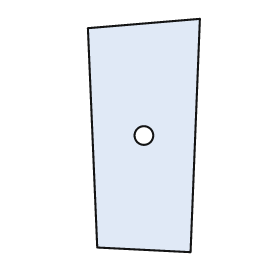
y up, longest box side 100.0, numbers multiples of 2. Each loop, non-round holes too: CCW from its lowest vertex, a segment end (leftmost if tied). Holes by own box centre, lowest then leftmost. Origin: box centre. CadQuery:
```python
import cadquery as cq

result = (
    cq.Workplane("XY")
    .moveTo(20.0, -50.0)
    .lineTo(24.0, 50.0)
    .lineTo(-24.0, 46.0)
    .lineTo(-20.0, -48.0)
    .close()
    .moveTo(0.0, 0.0)
    .circle(4.0)
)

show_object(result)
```